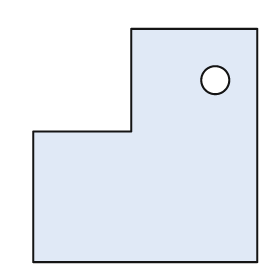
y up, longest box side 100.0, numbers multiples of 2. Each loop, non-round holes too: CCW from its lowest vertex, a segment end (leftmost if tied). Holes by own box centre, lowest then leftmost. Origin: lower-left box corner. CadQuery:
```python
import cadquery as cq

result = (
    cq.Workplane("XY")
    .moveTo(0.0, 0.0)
    .lineTo(96.0, 0.0)
    .lineTo(96.0, 100.0)
    .lineTo(42.0, 100.0)
    .lineTo(42.0, 56.0)
    .lineTo(0.0, 56.0)
    .close()
    .moveTo(78.0, 78.0)
    .circle(6.0)
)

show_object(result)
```